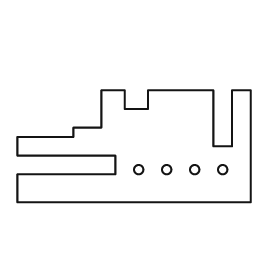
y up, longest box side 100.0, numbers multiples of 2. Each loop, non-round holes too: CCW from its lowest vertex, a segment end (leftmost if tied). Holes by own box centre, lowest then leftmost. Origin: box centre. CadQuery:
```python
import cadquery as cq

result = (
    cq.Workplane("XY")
    .moveTo(-50.0, -24.0)
    .lineTo(50.0, -24.0)
    .lineTo(50.0, 24.0)
    .lineTo(42.0, 24.0)
    .lineTo(42.0, 0.0)
    .lineTo(34.0, 0.0)
    .lineTo(34.0, 24.0)
    .lineTo(6.0, 24.0)
    .lineTo(6.0, 16.0)
    .lineTo(-4.0, 16.0)
    .lineTo(-4.0, 24.0)
    .lineTo(-14.0, 24.0)
    .lineTo(-14.0, 8.0)
    .lineTo(-26.0, 8.0)
    .lineTo(-26.0, 4.0)
    .lineTo(-50.0, 4.0)
    .lineTo(-50.0, -4.0)
    .lineTo(-8.0, -4.0)
    .lineTo(-8.0, -12.0)
    .lineTo(-50.0, -12.0)
    .close()
    .moveTo(2.0, -10.0)
    .circle(2.0)
    .moveTo(14.0, -10.0)
    .circle(2.0)
    .moveTo(26.0, -10.0)
    .circle(2.0)
    .moveTo(38.0, -10.0)
    .circle(2.0)
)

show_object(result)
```